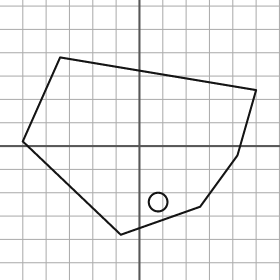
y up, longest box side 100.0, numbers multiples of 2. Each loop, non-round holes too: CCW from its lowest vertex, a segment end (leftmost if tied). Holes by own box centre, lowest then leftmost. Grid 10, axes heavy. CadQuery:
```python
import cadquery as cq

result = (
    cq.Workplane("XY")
    .moveTo(-8.0, -38.0)
    .lineTo(26.0, -26.0)
    .lineTo(42.0, -4.0)
    .lineTo(50.0, 24.0)
    .lineTo(-34.0, 38.0)
    .lineTo(-50.0, 2.0)
    .close()
    .moveTo(8.0, -24.0)
    .circle(4.0)
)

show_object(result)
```